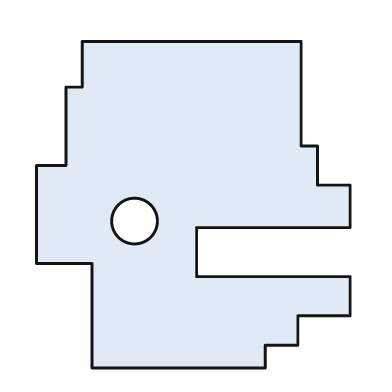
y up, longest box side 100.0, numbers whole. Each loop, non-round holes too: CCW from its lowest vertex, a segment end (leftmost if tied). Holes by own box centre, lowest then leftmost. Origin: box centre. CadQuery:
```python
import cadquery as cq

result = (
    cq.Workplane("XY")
    .moveTo(-31.0, -50.0)
    .lineTo(22.0, -50.0)
    .lineTo(22.0, -43.0)
    .lineTo(32.0, -43.0)
    .lineTo(32.0, -34.0)
    .lineTo(48.0, -34.0)
    .lineTo(48.0, -22.0)
    .lineTo(1.0, -22.0)
    .lineTo(1.0, -7.0)
    .lineTo(48.0, -7.0)
    .lineTo(48.0, 6.0)
    .lineTo(38.0, 6.0)
    .lineTo(38.0, 18.0)
    .lineTo(33.0, 18.0)
    .lineTo(33.0, 50.0)
    .lineTo(-34.0, 50.0)
    .lineTo(-34.0, 36.0)
    .lineTo(-39.0, 36.0)
    .lineTo(-39.0, 12.0)
    .lineTo(-48.0, 12.0)
    .lineTo(-48.0, -18.0)
    .lineTo(-31.0, -18.0)
    .close()
    .moveTo(-18.0, -5.0)
    .circle(7.0)
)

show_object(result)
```